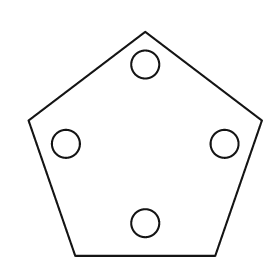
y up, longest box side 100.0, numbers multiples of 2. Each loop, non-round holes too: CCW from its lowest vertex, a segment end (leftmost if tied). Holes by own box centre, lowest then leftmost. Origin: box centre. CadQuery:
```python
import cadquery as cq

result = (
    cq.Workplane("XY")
    .moveTo(-30.0, -48.0)
    .lineTo(30.0, -48.0)
    .lineTo(50.0, 10.0)
    .lineTo(0.0, 48.0)
    .lineTo(-50.0, 10.0)
    .close()
    .moveTo(0.0, -34.0)
    .circle(6.0)
    .moveTo(-34.0, 0.0)
    .circle(6.0)
    .moveTo(34.0, 0.0)
    .circle(6.0)
    .moveTo(0.0, 34.0)
    .circle(6.0)
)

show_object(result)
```